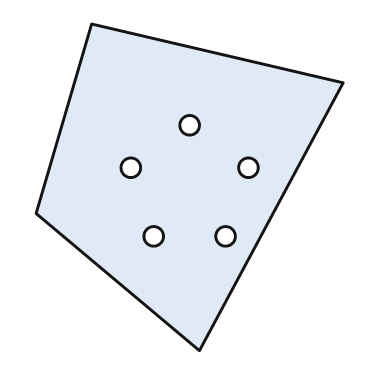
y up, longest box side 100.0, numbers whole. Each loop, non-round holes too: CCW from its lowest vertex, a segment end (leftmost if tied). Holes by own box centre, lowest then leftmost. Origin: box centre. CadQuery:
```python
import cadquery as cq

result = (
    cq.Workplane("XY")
    .moveTo(3.0, -50.0)
    .lineTo(47.0, 32.0)
    .lineTo(-30.0, 50.0)
    .lineTo(-47.0, -8.0)
    .close()
    .moveTo(-11.0, -15.0)
    .circle(3.0)
    .moveTo(11.0, -15.0)
    .circle(3.0)
    .moveTo(-18.0, 6.0)
    .circle(3.0)
    .moveTo(18.0, 6.0)
    .circle(3.0)
    .moveTo(0.0, 19.0)
    .circle(3.0)
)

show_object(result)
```